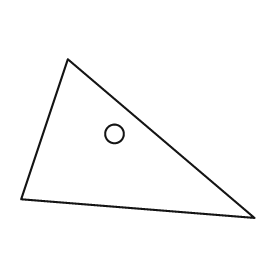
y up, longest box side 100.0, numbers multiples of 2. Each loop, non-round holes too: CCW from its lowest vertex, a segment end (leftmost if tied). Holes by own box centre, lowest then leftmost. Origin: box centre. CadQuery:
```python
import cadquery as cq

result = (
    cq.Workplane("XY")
    .moveTo(50.0, -34.0)
    .lineTo(-30.0, 34.0)
    .lineTo(-50.0, -26.0)
    .close()
    .moveTo(-10.0, 2.0)
    .circle(4.0)
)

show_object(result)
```